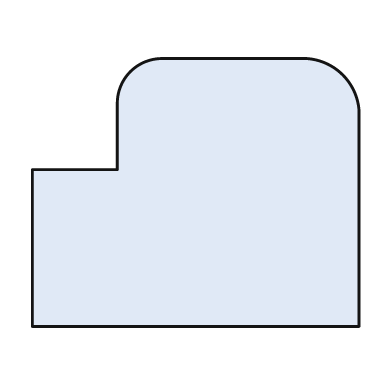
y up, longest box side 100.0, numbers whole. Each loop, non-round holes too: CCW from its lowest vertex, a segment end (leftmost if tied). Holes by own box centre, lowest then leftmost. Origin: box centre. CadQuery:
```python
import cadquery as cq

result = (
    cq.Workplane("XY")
    .moveTo(-50.0, -41.0)
    .lineTo(50.0, -41.0)
    .lineTo(50.0, 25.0)
    .threePointArc((45.0, 36.0), (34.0, 41.0))
    .lineTo(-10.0, 41.0)
    .threePointArc((-20.0, 37.0), (-24.0, 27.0))
    .lineTo(-24.0, 7.0)
    .lineTo(-50.0, 7.0)
    .close()
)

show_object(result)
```